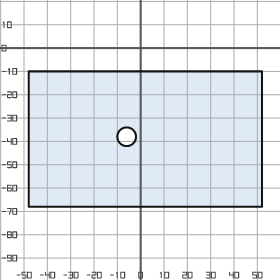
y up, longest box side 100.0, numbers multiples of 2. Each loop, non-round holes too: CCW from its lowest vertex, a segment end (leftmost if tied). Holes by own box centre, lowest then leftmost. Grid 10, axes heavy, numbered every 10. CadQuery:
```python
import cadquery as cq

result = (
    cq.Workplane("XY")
    .moveTo(-48.0, -68.0)
    .lineTo(52.0, -68.0)
    .lineTo(52.0, -10.0)
    .lineTo(-48.0, -10.0)
    .close()
    .moveTo(-6.0, -38.0)
    .circle(4.0)
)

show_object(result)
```